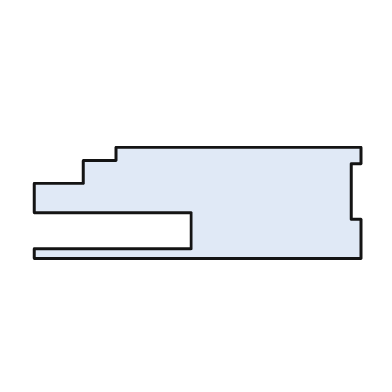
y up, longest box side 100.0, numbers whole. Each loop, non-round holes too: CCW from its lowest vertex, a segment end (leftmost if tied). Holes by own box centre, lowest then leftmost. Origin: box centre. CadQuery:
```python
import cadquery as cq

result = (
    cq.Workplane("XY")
    .moveTo(-50.0, -17.0)
    .lineTo(50.0, -17.0)
    .lineTo(50.0, -5.0)
    .lineTo(47.0, -5.0)
    .lineTo(47.0, 12.0)
    .lineTo(50.0, 12.0)
    .lineTo(50.0, 17.0)
    .lineTo(-25.0, 17.0)
    .lineTo(-25.0, 13.0)
    .lineTo(-35.0, 13.0)
    .lineTo(-35.0, 6.0)
    .lineTo(-50.0, 6.0)
    .lineTo(-50.0, -3.0)
    .lineTo(-2.0, -3.0)
    .lineTo(-2.0, -14.0)
    .lineTo(-50.0, -14.0)
    .close()
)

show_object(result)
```